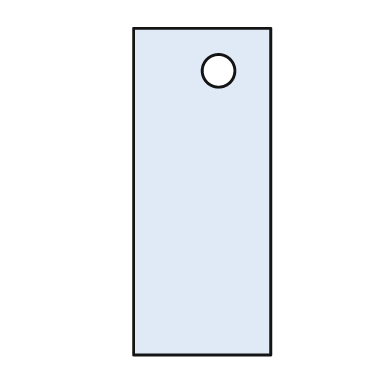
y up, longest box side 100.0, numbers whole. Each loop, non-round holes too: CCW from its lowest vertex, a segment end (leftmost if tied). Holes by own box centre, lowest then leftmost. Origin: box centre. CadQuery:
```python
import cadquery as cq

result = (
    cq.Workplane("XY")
    .moveTo(-21.0, -50.0)
    .lineTo(21.0, -50.0)
    .lineTo(21.0, 50.0)
    .lineTo(-21.0, 50.0)
    .close()
    .moveTo(5.0, 37.0)
    .circle(5.0)
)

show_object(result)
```